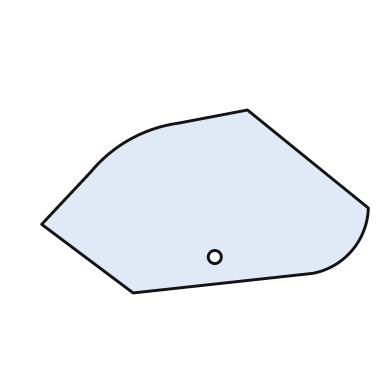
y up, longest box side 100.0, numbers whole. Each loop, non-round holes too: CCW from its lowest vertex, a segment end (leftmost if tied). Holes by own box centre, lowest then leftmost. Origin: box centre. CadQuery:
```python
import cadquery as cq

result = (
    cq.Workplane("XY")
    .moveTo(-22.0, -28.0)
    .lineTo(33.0, -22.0)
    .threePointArc((45.0, -15.0), (50.0, -2.0))
    .lineTo(13.0, 28.0)
    .lineTo(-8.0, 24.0)
    .threePointArc((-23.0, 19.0), (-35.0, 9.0))
    .lineTo(-50.0, -7.0)
    .close()
    .moveTo(3.0, -17.0)
    .circle(2.0)
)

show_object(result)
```